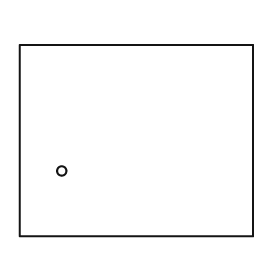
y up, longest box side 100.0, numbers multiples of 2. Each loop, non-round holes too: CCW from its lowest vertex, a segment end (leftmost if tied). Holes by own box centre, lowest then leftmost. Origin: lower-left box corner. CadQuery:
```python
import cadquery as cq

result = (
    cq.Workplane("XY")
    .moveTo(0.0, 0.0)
    .lineTo(100.0, 0.0)
    .lineTo(100.0, 82.0)
    .lineTo(0.0, 82.0)
    .close()
    .moveTo(18.0, 28.0)
    .circle(2.0)
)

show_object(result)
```